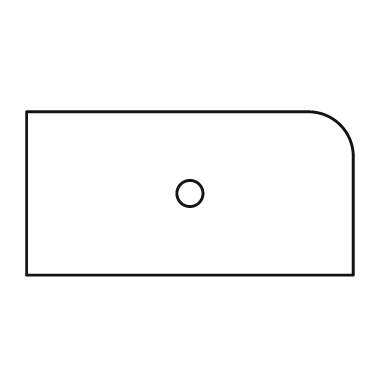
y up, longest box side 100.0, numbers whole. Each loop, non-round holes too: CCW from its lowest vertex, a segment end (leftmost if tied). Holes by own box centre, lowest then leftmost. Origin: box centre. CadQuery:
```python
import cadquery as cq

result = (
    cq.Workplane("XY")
    .moveTo(-50.0, -25.0)
    .lineTo(50.0, -25.0)
    .lineTo(50.0, 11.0)
    .threePointArc((46.0, 21.0), (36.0, 25.0))
    .lineTo(-50.0, 25.0)
    .close()
    .moveTo(0.0, 0.0)
    .circle(4.0)
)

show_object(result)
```